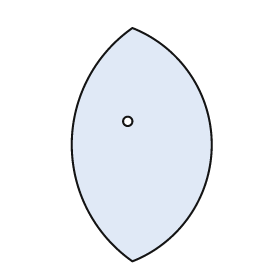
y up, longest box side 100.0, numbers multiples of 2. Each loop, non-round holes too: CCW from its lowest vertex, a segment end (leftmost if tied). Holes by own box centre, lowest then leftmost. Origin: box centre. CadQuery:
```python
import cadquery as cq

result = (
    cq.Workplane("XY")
    .moveTo(-4.0, -50.0)
    .threePointArc((30.0, 0.0), (-4.0, 50.0))
    .threePointArc((-30.0, 0.0), (-4.0, -50.0))
    .close()
    .moveTo(-6.0, 10.0)
    .circle(2.0)
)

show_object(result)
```